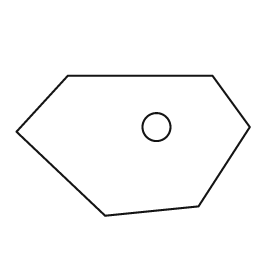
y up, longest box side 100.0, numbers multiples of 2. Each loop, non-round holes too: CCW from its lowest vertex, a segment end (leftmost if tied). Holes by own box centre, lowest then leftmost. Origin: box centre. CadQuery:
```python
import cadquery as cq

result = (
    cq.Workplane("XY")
    .moveTo(-12.0, -30.0)
    .lineTo(28.0, -26.0)
    .lineTo(50.0, 8.0)
    .lineTo(34.0, 30.0)
    .lineTo(-28.0, 30.0)
    .lineTo(-50.0, 6.0)
    .close()
    .moveTo(10.0, 8.0)
    .circle(6.0)
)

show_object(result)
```